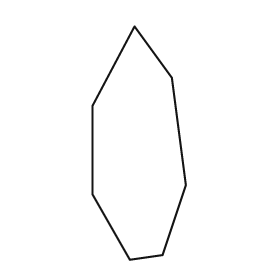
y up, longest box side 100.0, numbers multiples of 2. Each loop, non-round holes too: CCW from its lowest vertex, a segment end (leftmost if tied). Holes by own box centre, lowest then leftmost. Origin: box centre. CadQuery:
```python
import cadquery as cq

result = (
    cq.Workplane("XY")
    .moveTo(-4.0, -50.0)
    .lineTo(10.0, -48.0)
    .lineTo(20.0, -18.0)
    .lineTo(14.0, 28.0)
    .lineTo(-2.0, 50.0)
    .lineTo(-20.0, 16.0)
    .lineTo(-20.0, -22.0)
    .close()
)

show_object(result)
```